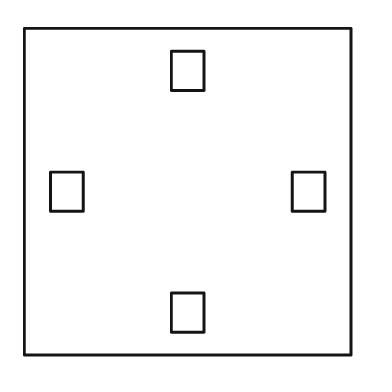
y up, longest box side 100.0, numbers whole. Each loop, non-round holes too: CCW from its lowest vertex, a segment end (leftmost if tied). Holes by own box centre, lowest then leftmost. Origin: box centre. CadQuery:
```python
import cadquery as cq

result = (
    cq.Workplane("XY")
    .moveTo(-50.0, -50.0)
    .lineTo(50.0, -50.0)
    .lineTo(50.0, 50.0)
    .lineTo(-50.0, 50.0)
    .close()
    .moveTo(-5.0, -43.0)
    .lineTo(5.0, -43.0)
    .lineTo(5.0, -31.0)
    .lineTo(-5.0, -31.0)
    .close()
    .moveTo(-42.0, -6.0)
    .lineTo(-32.0, -6.0)
    .lineTo(-32.0, 6.0)
    .lineTo(-42.0, 6.0)
    .close()
    .moveTo(32.0, -6.0)
    .lineTo(42.0, -6.0)
    .lineTo(42.0, 6.0)
    .lineTo(32.0, 6.0)
    .close()
    .moveTo(-5.0, 31.0)
    .lineTo(5.0, 31.0)
    .lineTo(5.0, 43.0)
    .lineTo(-5.0, 43.0)
    .close()
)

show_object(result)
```